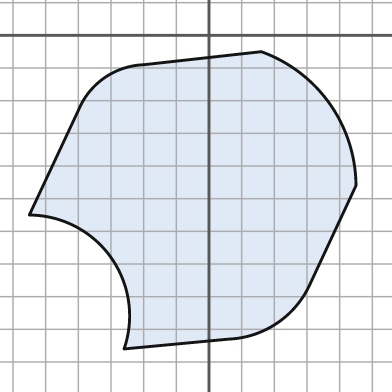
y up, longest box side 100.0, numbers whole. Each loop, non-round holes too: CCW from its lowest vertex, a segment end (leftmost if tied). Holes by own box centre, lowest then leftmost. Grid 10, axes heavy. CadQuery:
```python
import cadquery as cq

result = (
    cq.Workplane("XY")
    .moveTo(-26.0, -96.0)
    .lineTo(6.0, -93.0)
    .threePointArc((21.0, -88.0), (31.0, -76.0))
    .lineTo(45.0, -46.0)
    .threePointArc((37.0, -21.0), (16.0, -5.0))
    .lineTo(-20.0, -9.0)
    .threePointArc((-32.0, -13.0), (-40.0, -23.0))
    .lineTo(-55.0, -55.0)
    .threePointArc((-30.0, -68.0), (-26.0, -96.0))
    .close()
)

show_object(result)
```